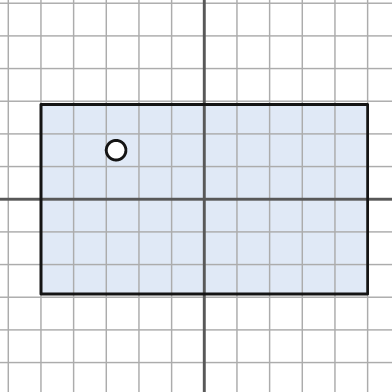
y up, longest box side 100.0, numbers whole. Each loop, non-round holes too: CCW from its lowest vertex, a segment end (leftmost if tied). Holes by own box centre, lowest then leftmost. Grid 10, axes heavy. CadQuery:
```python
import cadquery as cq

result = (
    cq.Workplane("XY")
    .moveTo(-50.0, -29.0)
    .lineTo(50.0, -29.0)
    .lineTo(50.0, 29.0)
    .lineTo(-50.0, 29.0)
    .close()
    .moveTo(-27.0, 15.0)
    .circle(3.0)
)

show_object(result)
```